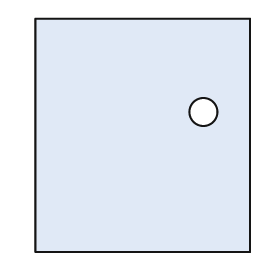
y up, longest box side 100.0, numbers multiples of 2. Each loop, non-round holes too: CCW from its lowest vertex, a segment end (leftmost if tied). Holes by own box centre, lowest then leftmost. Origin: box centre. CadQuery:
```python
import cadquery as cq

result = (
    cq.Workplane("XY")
    .moveTo(-46.0, -50.0)
    .lineTo(46.0, -50.0)
    .lineTo(46.0, 50.0)
    .lineTo(-46.0, 50.0)
    .close()
    .moveTo(26.0, 10.0)
    .circle(6.0)
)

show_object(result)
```